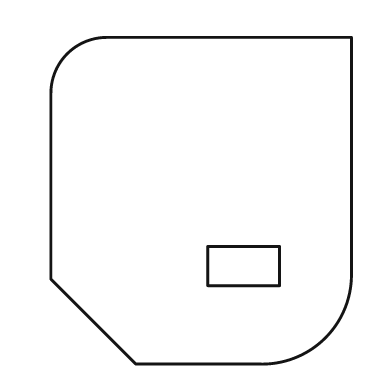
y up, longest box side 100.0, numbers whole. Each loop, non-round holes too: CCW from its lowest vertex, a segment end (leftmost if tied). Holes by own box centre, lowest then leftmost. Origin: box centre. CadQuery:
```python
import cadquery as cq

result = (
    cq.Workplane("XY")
    .moveTo(-20.0, -50.0)
    .lineTo(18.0, -50.0)
    .threePointArc((38.0, -42.0), (46.0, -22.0))
    .lineTo(46.0, 50.0)
    .lineTo(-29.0, 50.0)
    .threePointArc((-41.0, 45.0), (-46.0, 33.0))
    .lineTo(-46.0, -24.0)
    .close()
    .moveTo(2.0, -26.0)
    .lineTo(24.0, -26.0)
    .lineTo(24.0, -14.0)
    .lineTo(2.0, -14.0)
    .close()
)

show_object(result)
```